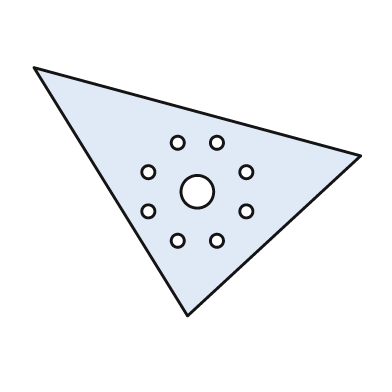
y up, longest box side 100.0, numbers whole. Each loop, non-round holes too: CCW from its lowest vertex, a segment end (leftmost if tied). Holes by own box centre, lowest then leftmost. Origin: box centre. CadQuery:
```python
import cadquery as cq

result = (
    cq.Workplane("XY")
    .moveTo(-3.0, -38.0)
    .lineTo(50.0, 11.0)
    .lineTo(-50.0, 38.0)
    .close()
    .moveTo(-6.0, -15.0)
    .circle(2.0)
    .moveTo(6.0, -15.0)
    .circle(2.0)
    .moveTo(-15.0, -6.0)
    .circle(2.0)
    .moveTo(15.0, -6.0)
    .circle(2.0)
    .moveTo(0.0, 0.0)
    .circle(5.0)
    .moveTo(-15.0, 6.0)
    .circle(2.0)
    .moveTo(15.0, 6.0)
    .circle(2.0)
    .moveTo(-6.0, 15.0)
    .circle(2.0)
    .moveTo(6.0, 15.0)
    .circle(2.0)
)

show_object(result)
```